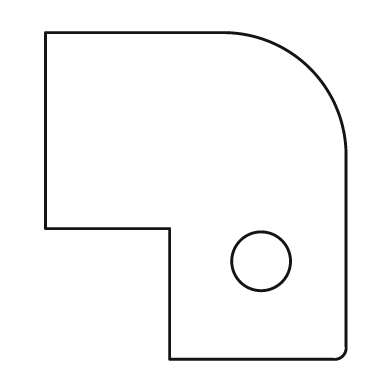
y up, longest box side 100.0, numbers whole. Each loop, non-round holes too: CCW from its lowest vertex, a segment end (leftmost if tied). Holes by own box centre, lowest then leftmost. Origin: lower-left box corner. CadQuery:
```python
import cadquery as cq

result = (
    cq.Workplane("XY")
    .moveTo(38.0, 0.0)
    .lineTo(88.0, 0.0)
    .threePointArc((91.0, 1.0), (92.0, 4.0))
    .lineTo(92.0, 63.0)
    .threePointArc((81.0, 89.0), (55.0, 100.0))
    .lineTo(0.0, 100.0)
    .lineTo(0.0, 40.0)
    .lineTo(38.0, 40.0)
    .close()
    .moveTo(66.0, 30.0)
    .circle(9.0)
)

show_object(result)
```